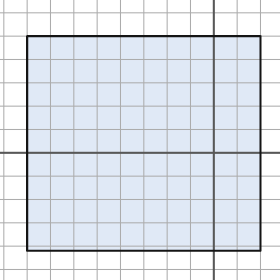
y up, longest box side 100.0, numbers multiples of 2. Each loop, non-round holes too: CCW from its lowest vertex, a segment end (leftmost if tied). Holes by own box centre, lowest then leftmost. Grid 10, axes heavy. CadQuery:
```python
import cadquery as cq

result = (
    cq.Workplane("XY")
    .moveTo(-80.0, -42.0)
    .lineTo(20.0, -42.0)
    .lineTo(20.0, 50.0)
    .lineTo(-80.0, 50.0)
    .close()
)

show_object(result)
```